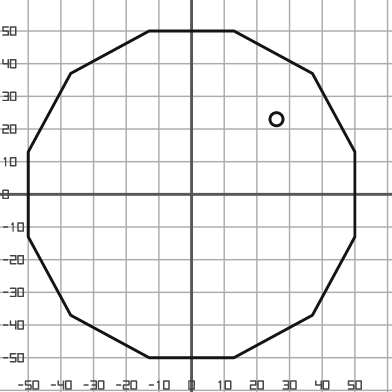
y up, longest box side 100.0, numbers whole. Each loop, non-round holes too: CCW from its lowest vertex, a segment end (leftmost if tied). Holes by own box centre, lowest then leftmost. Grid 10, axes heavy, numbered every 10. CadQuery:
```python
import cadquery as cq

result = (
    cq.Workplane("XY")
    .moveTo(-13.0, -50.0)
    .lineTo(13.0, -50.0)
    .lineTo(37.0, -37.0)
    .lineTo(50.0, -13.0)
    .lineTo(50.0, 13.0)
    .lineTo(37.0, 37.0)
    .lineTo(13.0, 50.0)
    .lineTo(-13.0, 50.0)
    .lineTo(-37.0, 37.0)
    .lineTo(-50.0, 13.0)
    .lineTo(-50.0, -13.0)
    .lineTo(-37.0, -37.0)
    .close()
    .moveTo(26.0, 23.0)
    .circle(2.0)
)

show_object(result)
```